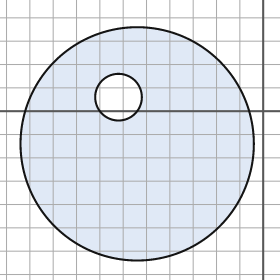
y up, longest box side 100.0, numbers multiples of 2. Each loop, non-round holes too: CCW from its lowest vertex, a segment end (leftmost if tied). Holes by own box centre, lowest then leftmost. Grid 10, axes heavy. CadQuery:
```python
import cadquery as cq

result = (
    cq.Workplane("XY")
    .moveTo(-54.0, -14.0)
    .circle(50.0)
    .moveTo(-62.0, 6.0)
    .circle(10.0)
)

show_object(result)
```